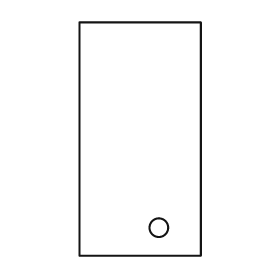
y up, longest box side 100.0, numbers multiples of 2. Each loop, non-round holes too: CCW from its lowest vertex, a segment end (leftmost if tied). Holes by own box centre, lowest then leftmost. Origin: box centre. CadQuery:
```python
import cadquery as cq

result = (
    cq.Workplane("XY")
    .moveTo(-26.0, -50.0)
    .lineTo(26.0, -50.0)
    .lineTo(26.0, 50.0)
    .lineTo(-26.0, 50.0)
    .close()
    .moveTo(8.0, -38.0)
    .circle(4.0)
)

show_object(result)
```